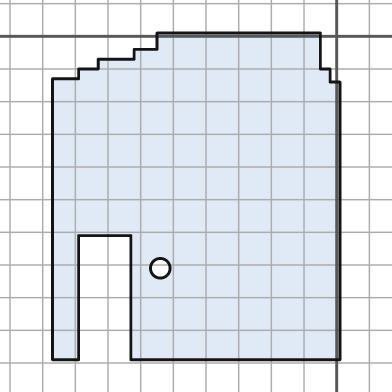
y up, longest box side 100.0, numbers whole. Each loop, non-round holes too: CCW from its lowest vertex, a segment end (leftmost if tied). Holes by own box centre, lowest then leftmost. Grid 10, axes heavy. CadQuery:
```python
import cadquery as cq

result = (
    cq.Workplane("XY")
    .moveTo(-87.0, -99.0)
    .lineTo(-79.0, -99.0)
    .lineTo(-79.0, -61.0)
    .lineTo(-63.0, -61.0)
    .lineTo(-63.0, -99.0)
    .lineTo(1.0, -99.0)
    .lineTo(1.0, -14.0)
    .lineTo(-2.0, -14.0)
    .lineTo(-2.0, -10.0)
    .lineTo(-5.0, -10.0)
    .lineTo(-5.0, 1.0)
    .lineTo(-55.0, 1.0)
    .lineTo(-55.0, -4.0)
    .lineTo(-62.0, -4.0)
    .lineTo(-62.0, -7.0)
    .lineTo(-73.0, -7.0)
    .lineTo(-73.0, -10.0)
    .lineTo(-79.0, -10.0)
    .lineTo(-79.0, -13.0)
    .lineTo(-87.0, -13.0)
    .close()
    .moveTo(-54.0, -71.0)
    .circle(3.0)
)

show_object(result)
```